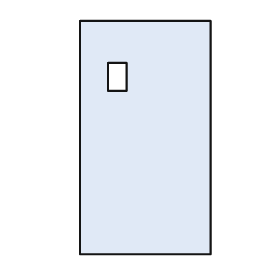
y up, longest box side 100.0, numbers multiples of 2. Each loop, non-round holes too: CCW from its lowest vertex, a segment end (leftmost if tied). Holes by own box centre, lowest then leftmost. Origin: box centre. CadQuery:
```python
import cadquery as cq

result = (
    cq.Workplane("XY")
    .moveTo(-28.0, -50.0)
    .lineTo(28.0, -50.0)
    .lineTo(28.0, 50.0)
    .lineTo(-28.0, 50.0)
    .close()
    .moveTo(-16.0, 20.0)
    .lineTo(-8.0, 20.0)
    .lineTo(-8.0, 32.0)
    .lineTo(-16.0, 32.0)
    .close()
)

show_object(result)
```